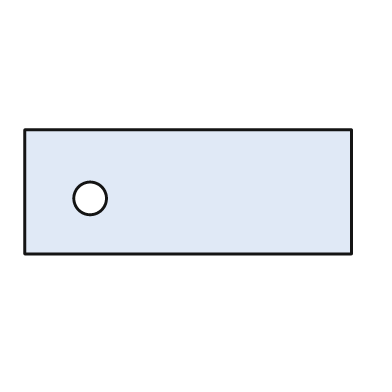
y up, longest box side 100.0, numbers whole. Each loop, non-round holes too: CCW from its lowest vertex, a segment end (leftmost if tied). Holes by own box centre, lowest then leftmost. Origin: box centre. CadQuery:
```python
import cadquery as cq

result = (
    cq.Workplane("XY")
    .moveTo(-50.0, -19.0)
    .lineTo(50.0, -19.0)
    .lineTo(50.0, 19.0)
    .lineTo(-50.0, 19.0)
    .close()
    .moveTo(-30.0, -2.0)
    .circle(5.0)
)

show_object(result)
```